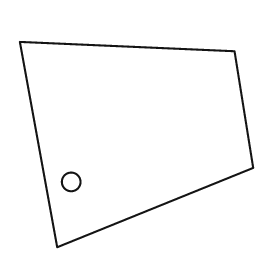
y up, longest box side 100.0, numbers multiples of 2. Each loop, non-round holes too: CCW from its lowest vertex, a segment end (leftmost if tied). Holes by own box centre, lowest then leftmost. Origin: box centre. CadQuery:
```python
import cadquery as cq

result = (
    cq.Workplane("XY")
    .moveTo(-34.0, -44.0)
    .lineTo(50.0, -10.0)
    .lineTo(42.0, 40.0)
    .lineTo(-50.0, 44.0)
    .close()
    .moveTo(-28.0, -16.0)
    .circle(4.0)
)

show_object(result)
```